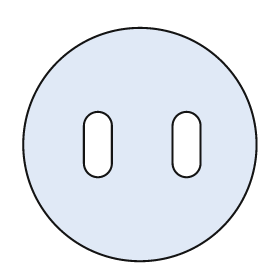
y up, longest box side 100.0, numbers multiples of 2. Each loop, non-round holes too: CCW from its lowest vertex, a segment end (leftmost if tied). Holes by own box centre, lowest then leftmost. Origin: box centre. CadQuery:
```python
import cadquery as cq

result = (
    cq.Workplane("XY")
    .moveTo(0.0, 0.0)
    .circle(50.0)
    .moveTo(-24.0, -8.0)
    .threePointArc((-18.0, -14.0), (-12.0, -8.0))
    .lineTo(-12.0, 8.0)
    .threePointArc((-18.0, 14.0), (-24.0, 8.0))
    .close()
    .moveTo(14.0, -8.0)
    .threePointArc((20.0, -14.0), (26.0, -8.0))
    .lineTo(26.0, 8.0)
    .threePointArc((20.0, 14.0), (14.0, 8.0))
    .close()
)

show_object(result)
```